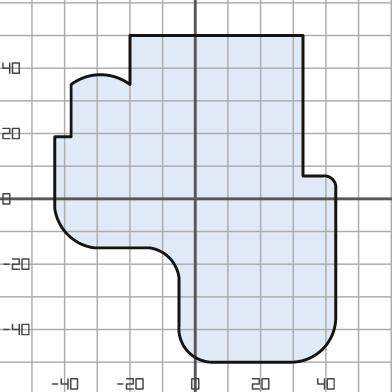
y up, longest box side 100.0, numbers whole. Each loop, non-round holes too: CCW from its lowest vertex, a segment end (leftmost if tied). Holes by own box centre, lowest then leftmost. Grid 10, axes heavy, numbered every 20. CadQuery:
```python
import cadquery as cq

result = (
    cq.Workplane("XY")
    .moveTo(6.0, -50.0)
    .lineTo(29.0, -50.0)
    .threePointArc((39.0, -46.0), (43.0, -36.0))
    .lineTo(43.0, 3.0)
    .threePointArc((42.0, 6.0), (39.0, 7.0))
    .lineTo(33.0, 7.0)
    .lineTo(33.0, 50.0)
    .lineTo(-20.0, 50.0)
    .lineTo(-20.0, 35.0)
    .threePointArc((-29.0, 38.0), (-38.0, 35.0))
    .lineTo(-38.0, 19.0)
    .lineTo(-43.0, 19.0)
    .lineTo(-43.0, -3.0)
    .threePointArc((-39.0, -11.0), (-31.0, -15.0))
    .lineTo(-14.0, -15.0)
    .threePointArc((-8.0, -18.0), (-5.0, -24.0))
    .lineTo(-5.0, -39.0)
    .threePointArc((-2.0, -47.0), (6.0, -50.0))
    .close()
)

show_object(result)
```